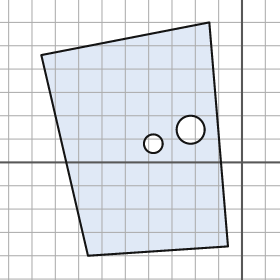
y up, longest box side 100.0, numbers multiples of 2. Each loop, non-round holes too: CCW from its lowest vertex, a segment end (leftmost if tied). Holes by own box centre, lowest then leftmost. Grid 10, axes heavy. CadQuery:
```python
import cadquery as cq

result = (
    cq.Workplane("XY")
    .moveTo(-66.0, -40.0)
    .lineTo(-6.0, -36.0)
    .lineTo(-14.0, 60.0)
    .lineTo(-86.0, 46.0)
    .close()
    .moveTo(-38.0, 8.0)
    .circle(4.0)
    .moveTo(-22.0, 14.0)
    .circle(6.0)
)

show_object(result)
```